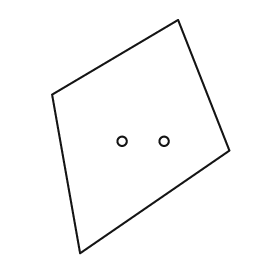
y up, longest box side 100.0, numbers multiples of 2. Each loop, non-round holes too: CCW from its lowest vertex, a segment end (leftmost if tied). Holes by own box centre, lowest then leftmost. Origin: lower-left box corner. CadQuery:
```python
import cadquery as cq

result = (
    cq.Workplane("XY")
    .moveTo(12.0, 0.0)
    .lineTo(76.0, 44.0)
    .lineTo(54.0, 100.0)
    .lineTo(0.0, 68.0)
    .close()
    .moveTo(30.0, 48.0)
    .circle(2.0)
    .moveTo(48.0, 48.0)
    .circle(2.0)
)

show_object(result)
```